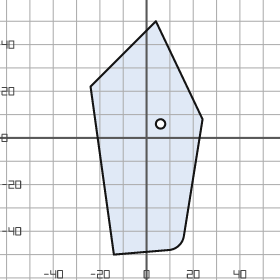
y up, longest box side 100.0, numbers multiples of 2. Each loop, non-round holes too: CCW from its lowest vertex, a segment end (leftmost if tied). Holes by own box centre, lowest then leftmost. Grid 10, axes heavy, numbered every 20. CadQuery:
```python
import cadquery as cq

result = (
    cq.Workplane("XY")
    .moveTo(-14.0, -50.0)
    .lineTo(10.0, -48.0)
    .threePointArc((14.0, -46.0), (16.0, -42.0))
    .lineTo(24.0, 8.0)
    .lineTo(4.0, 50.0)
    .lineTo(-24.0, 22.0)
    .close()
    .moveTo(6.0, 6.0)
    .circle(2.0)
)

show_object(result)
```